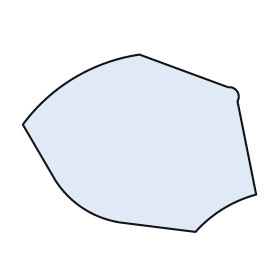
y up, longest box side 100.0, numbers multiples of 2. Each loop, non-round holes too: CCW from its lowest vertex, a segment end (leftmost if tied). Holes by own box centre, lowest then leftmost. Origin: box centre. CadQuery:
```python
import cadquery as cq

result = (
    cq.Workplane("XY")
    .moveTo(24.0, -38.0)
    .threePointArc((36.0, -28.0), (50.0, -22.0))
    .lineTo(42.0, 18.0)
    .threePointArc((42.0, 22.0), (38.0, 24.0))
    .lineTo(0.0, 38.0)
    .threePointArc((-28.0, 28.0), (-50.0, 8.0))
    .lineTo(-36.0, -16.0)
    .threePointArc((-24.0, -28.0), (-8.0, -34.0))
    .close()
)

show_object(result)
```